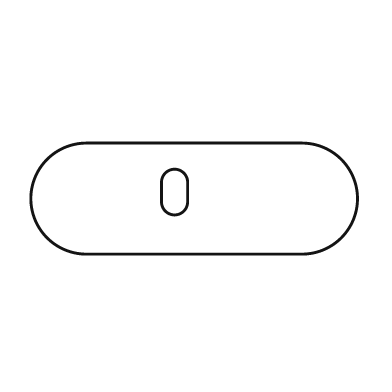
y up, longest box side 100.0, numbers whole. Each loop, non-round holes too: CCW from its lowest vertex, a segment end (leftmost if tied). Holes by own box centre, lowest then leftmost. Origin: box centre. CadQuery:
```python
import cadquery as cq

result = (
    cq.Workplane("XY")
    .moveTo(-33.0, -17.0)
    .lineTo(33.0, -17.0)
    .threePointArc((50.0, 0.0), (33.0, 17.0))
    .lineTo(-33.0, 17.0)
    .threePointArc((-50.0, 0.0), (-33.0, -17.0))
    .close()
    .moveTo(-10.0, -1.0)
    .threePointArc((-6.0, -5.0), (-2.0, -1.0))
    .lineTo(-2.0, 5.0)
    .threePointArc((-6.0, 9.0), (-10.0, 5.0))
    .close()
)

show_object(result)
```